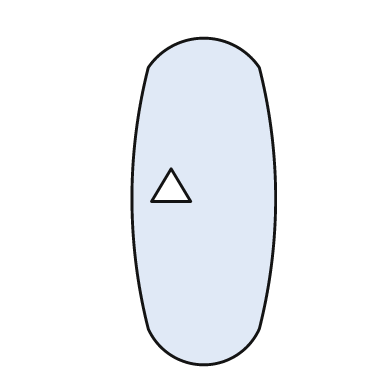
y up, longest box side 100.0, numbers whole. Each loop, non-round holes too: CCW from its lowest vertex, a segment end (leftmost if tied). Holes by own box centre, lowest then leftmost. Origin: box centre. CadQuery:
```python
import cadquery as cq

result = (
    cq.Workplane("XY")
    .moveTo(-17.0, -39.0)
    .threePointArc((0.0, -50.0), (17.0, -39.0))
    .threePointArc((22.0, 1.0), (17.0, 41.0))
    .threePointArc((0.0, 50.0), (-17.0, 41.0))
    .threePointArc((-22.0, 1.0), (-17.0, -39.0))
    .close()
    .moveTo(-16.0, 0.0)
    .lineTo(-4.0, 0.0)
    .lineTo(-10.0, 10.0)
    .close()
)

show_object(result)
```